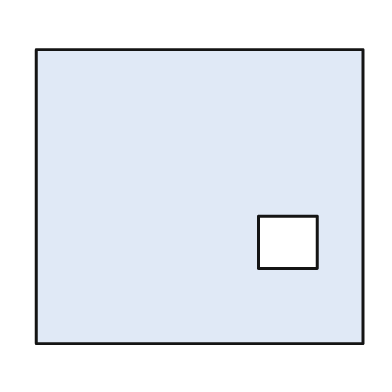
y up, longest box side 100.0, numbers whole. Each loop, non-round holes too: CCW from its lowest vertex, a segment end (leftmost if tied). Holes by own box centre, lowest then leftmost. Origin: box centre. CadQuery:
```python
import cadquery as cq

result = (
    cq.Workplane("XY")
    .moveTo(-50.0, -45.0)
    .lineTo(50.0, -45.0)
    .lineTo(50.0, 45.0)
    .lineTo(-50.0, 45.0)
    .close()
    .moveTo(18.0, -22.0)
    .lineTo(36.0, -22.0)
    .lineTo(36.0, -6.0)
    .lineTo(18.0, -6.0)
    .close()
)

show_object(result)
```